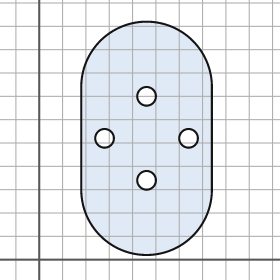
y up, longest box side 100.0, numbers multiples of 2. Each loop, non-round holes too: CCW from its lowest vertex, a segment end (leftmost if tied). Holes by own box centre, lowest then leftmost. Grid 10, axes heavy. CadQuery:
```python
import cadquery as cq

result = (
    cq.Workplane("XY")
    .moveTo(18.0, 30.0)
    .threePointArc((46.0, 2.0), (74.0, 30.0))
    .lineTo(74.0, 74.0)
    .threePointArc((46.0, 102.0), (18.0, 74.0))
    .close()
    .moveTo(46.0, 34.0)
    .circle(4.0)
    .moveTo(28.0, 52.0)
    .circle(4.0)
    .moveTo(64.0, 52.0)
    .circle(4.0)
    .moveTo(46.0, 70.0)
    .circle(4.0)
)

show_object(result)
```